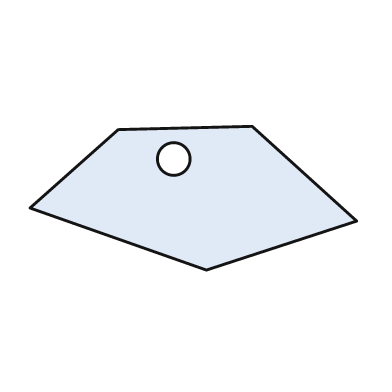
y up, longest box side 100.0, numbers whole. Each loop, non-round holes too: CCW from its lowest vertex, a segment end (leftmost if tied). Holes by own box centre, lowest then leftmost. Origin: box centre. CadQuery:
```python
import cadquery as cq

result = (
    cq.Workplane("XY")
    .moveTo(4.0, -22.0)
    .lineTo(50.0, -7.0)
    .lineTo(18.0, 22.0)
    .lineTo(-23.0, 21.0)
    .lineTo(-50.0, -3.0)
    .close()
    .moveTo(-6.0, 12.0)
    .circle(5.0)
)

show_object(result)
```